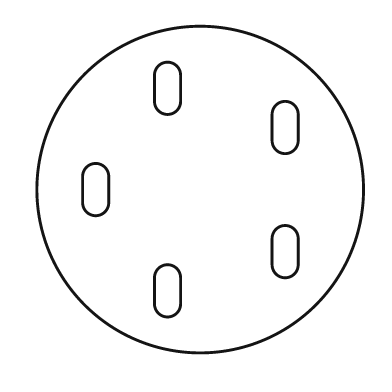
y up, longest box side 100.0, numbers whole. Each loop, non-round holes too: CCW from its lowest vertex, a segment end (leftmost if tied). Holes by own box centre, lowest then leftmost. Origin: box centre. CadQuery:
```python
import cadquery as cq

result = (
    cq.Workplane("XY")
    .moveTo(0.0, 0.0)
    .circle(50.0)
    .moveTo(-14.0, -35.0)
    .threePointArc((-10.0, -39.0), (-6.0, -35.0))
    .lineTo(-6.0, -27.0)
    .threePointArc((-10.0, -23.0), (-14.0, -27.0))
    .close()
    .moveTo(22.0, -23.0)
    .threePointArc((26.0, -27.0), (30.0, -23.0))
    .lineTo(30.0, -15.0)
    .threePointArc((26.0, -11.0), (22.0, -15.0))
    .close()
    .moveTo(-36.0, -4.0)
    .threePointArc((-32.0, -8.0), (-28.0, -4.0))
    .lineTo(-28.0, 4.0)
    .threePointArc((-32.0, 8.0), (-36.0, 4.0))
    .close()
    .moveTo(22.0, 15.0)
    .threePointArc((26.0, 11.0), (30.0, 15.0))
    .lineTo(30.0, 23.0)
    .threePointArc((26.0, 27.0), (22.0, 23.0))
    .close()
    .moveTo(-14.0, 27.0)
    .threePointArc((-10.0, 23.0), (-6.0, 27.0))
    .lineTo(-6.0, 35.0)
    .threePointArc((-10.0, 39.0), (-14.0, 35.0))
    .close()
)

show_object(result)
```